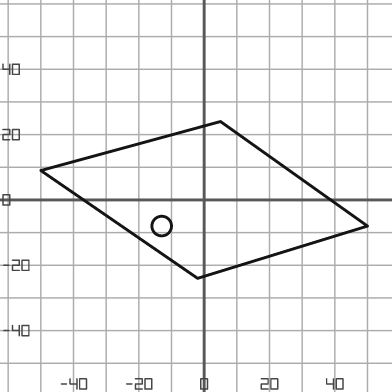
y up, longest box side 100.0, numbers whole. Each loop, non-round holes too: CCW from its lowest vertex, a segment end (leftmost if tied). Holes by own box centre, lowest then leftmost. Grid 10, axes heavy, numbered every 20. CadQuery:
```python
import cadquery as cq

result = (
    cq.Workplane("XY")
    .moveTo(-2.0, -24.0)
    .lineTo(50.0, -8.0)
    .lineTo(5.0, 24.0)
    .lineTo(-50.0, 9.0)
    .close()
    .moveTo(-13.0, -8.0)
    .circle(3.0)
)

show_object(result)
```